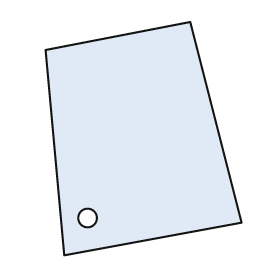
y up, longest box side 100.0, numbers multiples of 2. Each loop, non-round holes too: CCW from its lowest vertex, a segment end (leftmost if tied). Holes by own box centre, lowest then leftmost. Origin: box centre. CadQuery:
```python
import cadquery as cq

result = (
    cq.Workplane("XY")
    .moveTo(-34.0, -50.0)
    .lineTo(42.0, -36.0)
    .lineTo(20.0, 50.0)
    .lineTo(-42.0, 38.0)
    .close()
    .moveTo(-24.0, -34.0)
    .circle(4.0)
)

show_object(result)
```